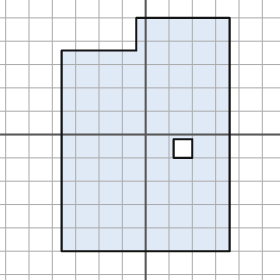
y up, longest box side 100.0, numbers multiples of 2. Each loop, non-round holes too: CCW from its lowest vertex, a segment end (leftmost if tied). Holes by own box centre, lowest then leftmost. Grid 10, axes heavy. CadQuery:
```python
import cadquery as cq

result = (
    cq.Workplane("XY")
    .moveTo(-36.0, -50.0)
    .lineTo(36.0, -50.0)
    .lineTo(36.0, 50.0)
    .lineTo(-4.0, 50.0)
    .lineTo(-4.0, 36.0)
    .lineTo(-36.0, 36.0)
    .close()
    .moveTo(12.0, -10.0)
    .lineTo(20.0, -10.0)
    .lineTo(20.0, -2.0)
    .lineTo(12.0, -2.0)
    .close()
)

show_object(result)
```